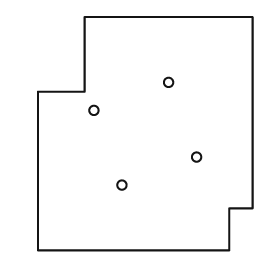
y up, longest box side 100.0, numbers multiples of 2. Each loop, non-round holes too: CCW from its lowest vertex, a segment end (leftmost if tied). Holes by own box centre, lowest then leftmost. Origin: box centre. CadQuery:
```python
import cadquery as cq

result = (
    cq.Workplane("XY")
    .moveTo(-46.0, -50.0)
    .lineTo(36.0, -50.0)
    .lineTo(36.0, -32.0)
    .lineTo(46.0, -32.0)
    .lineTo(46.0, 50.0)
    .lineTo(-26.0, 50.0)
    .lineTo(-26.0, 18.0)
    .lineTo(-46.0, 18.0)
    .close()
    .moveTo(-10.0, -22.0)
    .circle(2.0)
    .moveTo(22.0, -10.0)
    .circle(2.0)
    .moveTo(-22.0, 10.0)
    .circle(2.0)
    .moveTo(10.0, 22.0)
    .circle(2.0)
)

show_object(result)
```